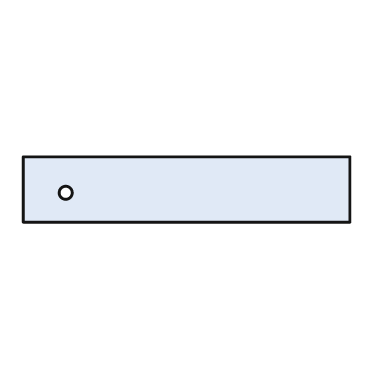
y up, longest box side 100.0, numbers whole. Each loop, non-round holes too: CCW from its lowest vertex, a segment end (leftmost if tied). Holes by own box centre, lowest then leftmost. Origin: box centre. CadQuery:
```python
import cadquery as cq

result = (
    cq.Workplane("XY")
    .moveTo(-50.0, -10.0)
    .lineTo(50.0, -10.0)
    .lineTo(50.0, 10.0)
    .lineTo(-50.0, 10.0)
    .close()
    .moveTo(-37.0, -1.0)
    .circle(2.0)
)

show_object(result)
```